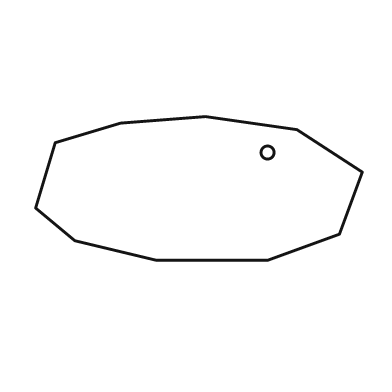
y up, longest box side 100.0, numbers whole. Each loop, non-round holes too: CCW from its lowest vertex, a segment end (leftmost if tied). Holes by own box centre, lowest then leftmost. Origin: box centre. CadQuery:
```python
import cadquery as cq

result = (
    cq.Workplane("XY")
    .moveTo(-13.0, -22.0)
    .lineTo(21.0, -22.0)
    .lineTo(43.0, -14.0)
    .lineTo(50.0, 5.0)
    .lineTo(30.0, 18.0)
    .lineTo(2.0, 22.0)
    .lineTo(-24.0, 20.0)
    .lineTo(-44.0, 14.0)
    .lineTo(-50.0, -6.0)
    .lineTo(-38.0, -16.0)
    .close()
    .moveTo(21.0, 11.0)
    .circle(2.0)
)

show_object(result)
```